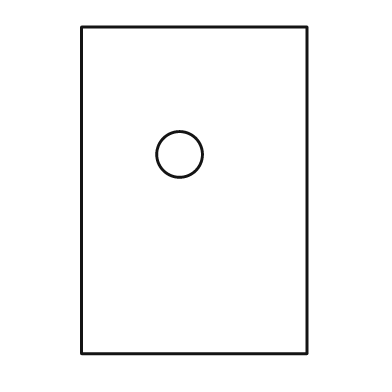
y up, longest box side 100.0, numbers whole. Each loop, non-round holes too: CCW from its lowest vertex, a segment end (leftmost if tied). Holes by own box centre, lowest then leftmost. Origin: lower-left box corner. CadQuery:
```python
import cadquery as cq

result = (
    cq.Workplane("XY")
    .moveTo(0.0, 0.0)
    .lineTo(69.0, 0.0)
    .lineTo(69.0, 100.0)
    .lineTo(0.0, 100.0)
    .close()
    .moveTo(30.0, 61.0)
    .circle(7.0)
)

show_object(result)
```